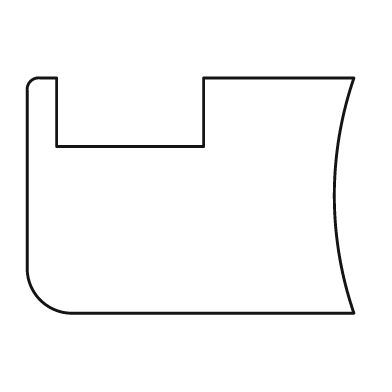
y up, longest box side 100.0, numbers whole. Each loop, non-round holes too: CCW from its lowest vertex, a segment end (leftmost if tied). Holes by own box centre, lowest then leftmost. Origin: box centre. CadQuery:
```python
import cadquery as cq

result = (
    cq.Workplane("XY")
    .moveTo(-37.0, -36.0)
    .lineTo(50.0, -36.0)
    .threePointArc((44.0, 0.0), (50.0, 36.0))
    .lineTo(4.0, 36.0)
    .lineTo(4.0, 15.0)
    .lineTo(-41.0, 15.0)
    .lineTo(-41.0, 36.0)
    .lineTo(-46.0, 36.0)
    .threePointArc((-49.0, 35.0), (-50.0, 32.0))
    .lineTo(-50.0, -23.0)
    .threePointArc((-46.0, -32.0), (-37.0, -36.0))
    .close()
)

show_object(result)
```